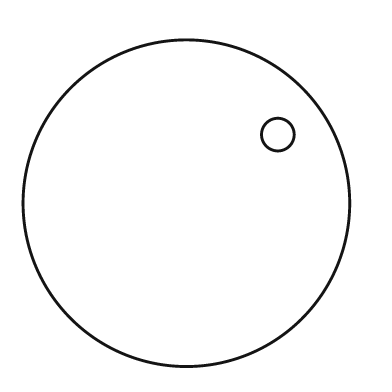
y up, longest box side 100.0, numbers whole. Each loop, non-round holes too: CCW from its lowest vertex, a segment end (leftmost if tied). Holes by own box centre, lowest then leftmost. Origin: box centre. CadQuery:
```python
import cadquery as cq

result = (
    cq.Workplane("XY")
    .moveTo(0.0, 0.0)
    .circle(50.0)
    .moveTo(28.0, 21.0)
    .circle(5.0)
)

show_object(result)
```